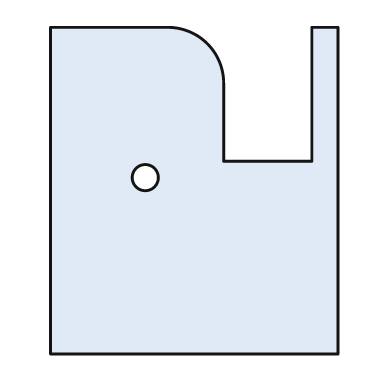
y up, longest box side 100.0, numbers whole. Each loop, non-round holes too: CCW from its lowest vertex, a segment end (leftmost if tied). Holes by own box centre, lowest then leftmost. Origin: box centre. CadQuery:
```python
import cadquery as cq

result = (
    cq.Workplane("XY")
    .moveTo(-44.0, -50.0)
    .lineTo(44.0, -50.0)
    .lineTo(44.0, 50.0)
    .lineTo(36.0, 50.0)
    .lineTo(36.0, 9.0)
    .lineTo(9.0, 9.0)
    .lineTo(9.0, 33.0)
    .threePointArc((4.0, 45.0), (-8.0, 50.0))
    .lineTo(-44.0, 50.0)
    .close()
    .moveTo(-15.0, 4.0)
    .circle(4.0)
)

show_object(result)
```